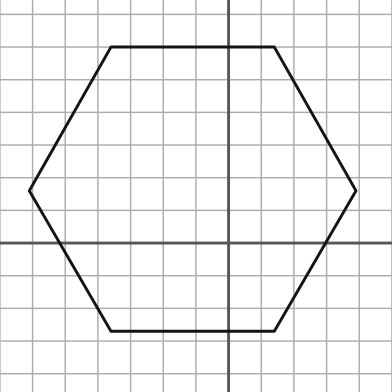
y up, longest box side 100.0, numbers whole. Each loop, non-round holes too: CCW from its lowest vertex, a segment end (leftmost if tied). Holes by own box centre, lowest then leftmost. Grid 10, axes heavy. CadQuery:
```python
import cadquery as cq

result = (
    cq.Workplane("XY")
    .moveTo(-36.0, -27.0)
    .lineTo(14.0, -27.0)
    .lineTo(39.0, 16.0)
    .lineTo(14.0, 60.0)
    .lineTo(-36.0, 60.0)
    .lineTo(-61.0, 16.0)
    .close()
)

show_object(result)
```